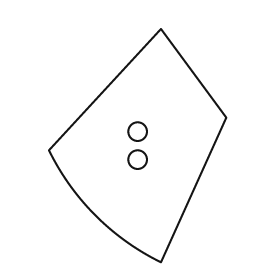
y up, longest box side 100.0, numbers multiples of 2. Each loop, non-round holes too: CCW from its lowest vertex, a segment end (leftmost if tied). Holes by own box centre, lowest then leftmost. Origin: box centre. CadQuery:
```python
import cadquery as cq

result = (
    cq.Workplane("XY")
    .moveTo(10.0, -50.0)
    .lineTo(38.0, 12.0)
    .lineTo(10.0, 50.0)
    .lineTo(-38.0, -2.0)
    .threePointArc((-18.0, -30.0), (10.0, -50.0))
    .close()
    .moveTo(0.0, -6.0)
    .circle(4.0)
    .moveTo(0.0, 6.0)
    .circle(4.0)
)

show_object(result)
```